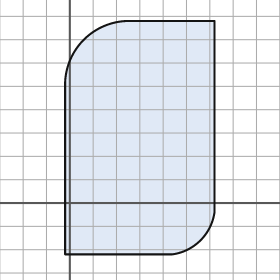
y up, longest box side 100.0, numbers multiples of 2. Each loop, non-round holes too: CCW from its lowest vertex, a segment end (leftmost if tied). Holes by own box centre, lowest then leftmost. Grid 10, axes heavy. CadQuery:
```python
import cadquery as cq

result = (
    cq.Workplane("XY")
    .moveTo(-2.0, -22.0)
    .lineTo(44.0, -22.0)
    .threePointArc((56.0, -16.0), (62.0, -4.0))
    .lineTo(62.0, 78.0)
    .lineTo(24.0, 78.0)
    .threePointArc((6.0, 70.0), (-2.0, 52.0))
    .close()
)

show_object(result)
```